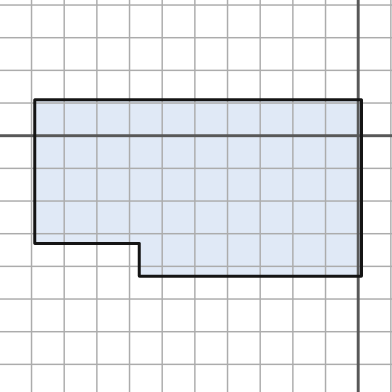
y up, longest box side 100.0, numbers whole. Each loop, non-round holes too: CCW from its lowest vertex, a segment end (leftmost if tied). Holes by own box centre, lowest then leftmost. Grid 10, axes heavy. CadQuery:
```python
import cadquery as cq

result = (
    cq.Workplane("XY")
    .moveTo(-67.0, -43.0)
    .lineTo(1.0, -43.0)
    .lineTo(1.0, 11.0)
    .lineTo(-99.0, 11.0)
    .lineTo(-99.0, -33.0)
    .lineTo(-67.0, -33.0)
    .close()
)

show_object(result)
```